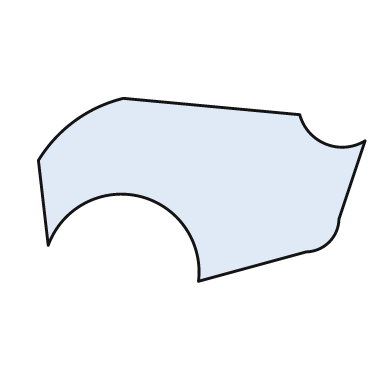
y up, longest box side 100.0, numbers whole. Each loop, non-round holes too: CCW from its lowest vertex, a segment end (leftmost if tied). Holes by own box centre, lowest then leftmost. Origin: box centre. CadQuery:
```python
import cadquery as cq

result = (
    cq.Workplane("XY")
    .moveTo(-1.0, -28.0)
    .lineTo(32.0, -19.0)
    .threePointArc((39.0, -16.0), (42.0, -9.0))
    .lineTo(50.0, 15.0)
    .threePointArc((38.0, 14.0), (30.0, 23.0))
    .lineTo(-24.0, 28.0)
    .threePointArc((-39.0, 21.0), (-50.0, 9.0))
    .lineTo(-47.0, -17.0)
    .threePointArc((-19.0, -2.0), (-1.0, -28.0))
    .close()
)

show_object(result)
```